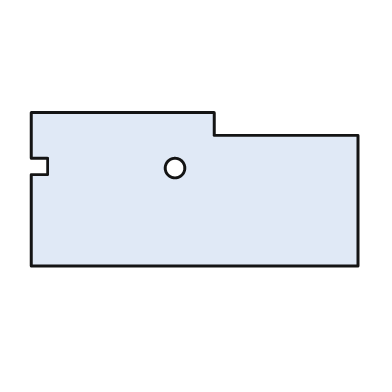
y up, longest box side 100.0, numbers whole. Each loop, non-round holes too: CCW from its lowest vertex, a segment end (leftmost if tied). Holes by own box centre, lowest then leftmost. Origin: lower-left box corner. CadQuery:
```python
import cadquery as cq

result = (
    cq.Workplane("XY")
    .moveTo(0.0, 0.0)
    .lineTo(100.0, 0.0)
    .lineTo(100.0, 40.0)
    .lineTo(56.0, 40.0)
    .lineTo(56.0, 47.0)
    .lineTo(0.0, 47.0)
    .lineTo(0.0, 33.0)
    .lineTo(5.0, 33.0)
    .lineTo(5.0, 28.0)
    .lineTo(0.0, 28.0)
    .close()
    .moveTo(44.0, 30.0)
    .circle(3.0)
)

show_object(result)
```